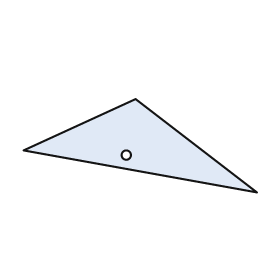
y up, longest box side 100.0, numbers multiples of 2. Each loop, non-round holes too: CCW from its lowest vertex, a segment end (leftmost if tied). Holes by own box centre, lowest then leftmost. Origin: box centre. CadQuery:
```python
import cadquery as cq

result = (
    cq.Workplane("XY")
    .moveTo(50.0, -20.0)
    .lineTo(-2.0, 20.0)
    .lineTo(-50.0, -2.0)
    .close()
    .moveTo(-6.0, -4.0)
    .circle(2.0)
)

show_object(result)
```